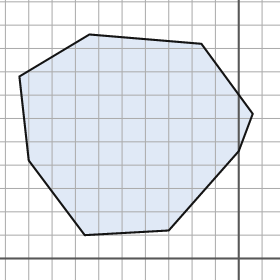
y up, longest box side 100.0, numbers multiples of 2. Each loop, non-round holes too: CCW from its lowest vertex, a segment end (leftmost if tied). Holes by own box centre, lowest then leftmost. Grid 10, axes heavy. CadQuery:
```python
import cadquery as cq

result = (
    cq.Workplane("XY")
    .moveTo(-66.0, 10.0)
    .lineTo(-30.0, 12.0)
    .lineTo(0.0, 46.0)
    .lineTo(6.0, 62.0)
    .lineTo(-16.0, 92.0)
    .lineTo(-64.0, 96.0)
    .lineTo(-94.0, 78.0)
    .lineTo(-90.0, 42.0)
    .close()
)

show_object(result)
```